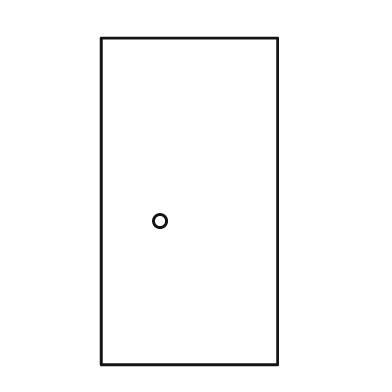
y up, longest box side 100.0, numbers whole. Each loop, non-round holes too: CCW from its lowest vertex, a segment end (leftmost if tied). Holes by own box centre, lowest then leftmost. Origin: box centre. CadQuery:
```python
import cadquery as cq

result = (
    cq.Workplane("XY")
    .moveTo(-27.0, -50.0)
    .lineTo(27.0, -50.0)
    .lineTo(27.0, 50.0)
    .lineTo(-27.0, 50.0)
    .close()
    .moveTo(-9.0, -6.0)
    .circle(2.0)
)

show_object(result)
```